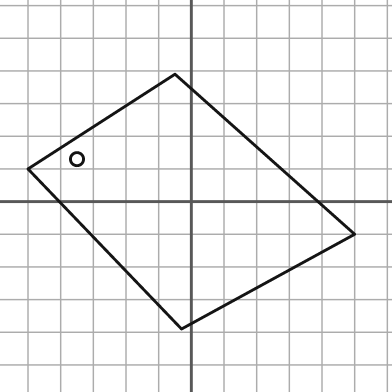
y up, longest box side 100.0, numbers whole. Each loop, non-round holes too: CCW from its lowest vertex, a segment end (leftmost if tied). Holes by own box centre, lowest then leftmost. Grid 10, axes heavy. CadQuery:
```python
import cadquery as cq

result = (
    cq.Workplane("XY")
    .moveTo(-3.0, -39.0)
    .lineTo(50.0, -10.0)
    .lineTo(-5.0, 39.0)
    .lineTo(-50.0, 10.0)
    .close()
    .moveTo(-35.0, 13.0)
    .circle(2.0)
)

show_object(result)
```